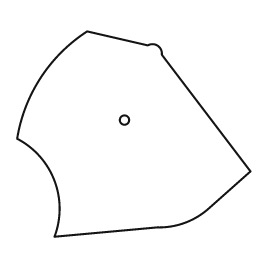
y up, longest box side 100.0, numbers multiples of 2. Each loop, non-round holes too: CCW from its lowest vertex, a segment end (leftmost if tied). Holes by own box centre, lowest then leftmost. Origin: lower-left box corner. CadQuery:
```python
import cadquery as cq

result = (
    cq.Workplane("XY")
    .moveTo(16.0, 0.0)
    .lineTo(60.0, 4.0)
    .threePointArc((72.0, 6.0), (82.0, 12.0))
    .lineTo(100.0, 28.0)
    .lineTo(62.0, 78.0)
    .threePointArc((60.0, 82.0), (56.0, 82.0))
    .lineTo(30.0, 88.0)
    .threePointArc((10.0, 68.0), (0.0, 42.0))
    .threePointArc((16.0, 24.0), (16.0, 0.0))
    .close()
    .moveTo(46.0, 50.0)
    .circle(2.0)
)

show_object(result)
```